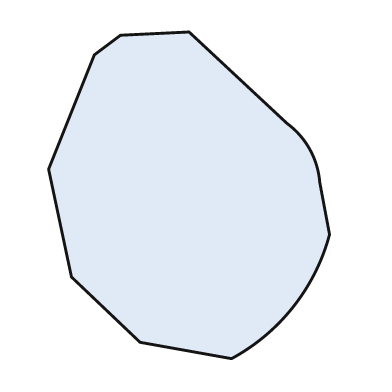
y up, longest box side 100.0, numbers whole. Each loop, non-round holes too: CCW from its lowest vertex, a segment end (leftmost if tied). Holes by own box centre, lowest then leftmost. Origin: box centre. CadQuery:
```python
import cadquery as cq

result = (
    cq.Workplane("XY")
    .moveTo(13.0, -50.0)
    .threePointArc((32.0, -34.0), (43.0, -12.0))
    .lineTo(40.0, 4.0)
    .threePointArc((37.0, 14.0), (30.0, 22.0))
    .lineTo(0.0, 50.0)
    .lineTo(-21.0, 49.0)
    .lineTo(-29.0, 43.0)
    .lineTo(-43.0, 8.0)
    .lineTo(-36.0, -25.0)
    .lineTo(-15.0, -45.0)
    .close()
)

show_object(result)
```